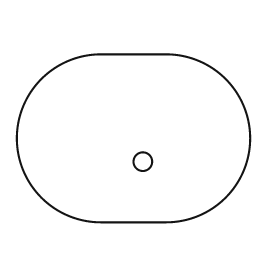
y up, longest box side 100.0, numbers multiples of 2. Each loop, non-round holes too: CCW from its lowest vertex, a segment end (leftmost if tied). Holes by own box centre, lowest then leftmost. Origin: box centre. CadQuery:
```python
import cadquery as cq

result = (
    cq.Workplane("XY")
    .moveTo(-14.0, -36.0)
    .lineTo(14.0, -36.0)
    .threePointArc((50.0, 0.0), (14.0, 36.0))
    .lineTo(-14.0, 36.0)
    .threePointArc((-50.0, 0.0), (-14.0, -36.0))
    .close()
    .moveTo(4.0, -10.0)
    .circle(4.0)
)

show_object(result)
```